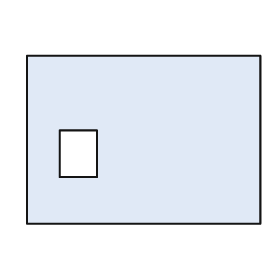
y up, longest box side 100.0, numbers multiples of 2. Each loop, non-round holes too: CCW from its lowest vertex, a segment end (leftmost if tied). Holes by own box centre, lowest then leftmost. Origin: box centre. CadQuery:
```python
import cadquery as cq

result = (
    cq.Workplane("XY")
    .moveTo(-50.0, -36.0)
    .lineTo(50.0, -36.0)
    .lineTo(50.0, 36.0)
    .lineTo(-50.0, 36.0)
    .close()
    .moveTo(-36.0, -16.0)
    .lineTo(-20.0, -16.0)
    .lineTo(-20.0, 4.0)
    .lineTo(-36.0, 4.0)
    .close()
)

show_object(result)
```